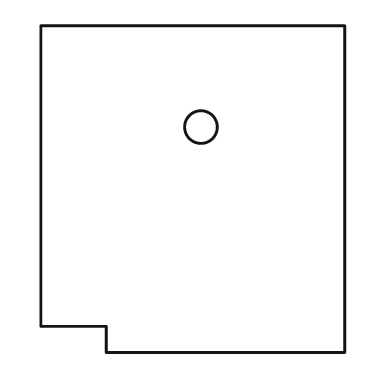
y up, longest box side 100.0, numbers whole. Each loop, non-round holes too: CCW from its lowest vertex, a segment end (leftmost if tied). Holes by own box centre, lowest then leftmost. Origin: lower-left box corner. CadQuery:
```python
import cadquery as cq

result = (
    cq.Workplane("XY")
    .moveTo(20.0, 0.0)
    .lineTo(93.0, 0.0)
    .lineTo(93.0, 100.0)
    .lineTo(0.0, 100.0)
    .lineTo(0.0, 8.0)
    .lineTo(20.0, 8.0)
    .close()
    .moveTo(49.0, 69.0)
    .circle(5.0)
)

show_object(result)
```